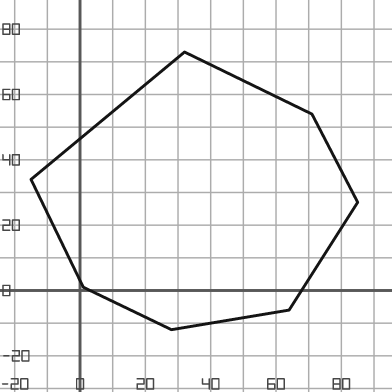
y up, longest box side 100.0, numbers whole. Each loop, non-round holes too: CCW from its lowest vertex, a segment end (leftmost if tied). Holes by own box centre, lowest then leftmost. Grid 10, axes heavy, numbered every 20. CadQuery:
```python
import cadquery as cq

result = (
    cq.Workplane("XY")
    .moveTo(28.0, -12.0)
    .lineTo(64.0, -6.0)
    .lineTo(85.0, 27.0)
    .lineTo(71.0, 54.0)
    .lineTo(32.0, 73.0)
    .lineTo(-15.0, 34.0)
    .lineTo(1.0, 1.0)
    .close()
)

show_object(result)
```